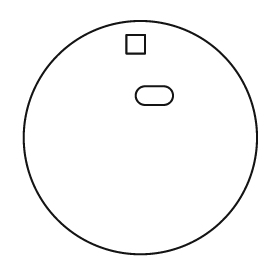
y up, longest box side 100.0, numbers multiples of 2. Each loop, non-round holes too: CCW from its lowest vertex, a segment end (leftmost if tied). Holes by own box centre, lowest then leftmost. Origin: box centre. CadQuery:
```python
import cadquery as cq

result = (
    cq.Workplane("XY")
    .moveTo(0.0, 0.0)
    .circle(50.0)
    .moveTo(2.0, 14.0)
    .lineTo(10.0, 14.0)
    .threePointArc((14.0, 18.0), (10.0, 22.0))
    .lineTo(2.0, 22.0)
    .threePointArc((-2.0, 18.0), (2.0, 14.0))
    .close()
    .moveTo(-6.0, 36.0)
    .lineTo(2.0, 36.0)
    .lineTo(2.0, 44.0)
    .lineTo(-6.0, 44.0)
    .close()
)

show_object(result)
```